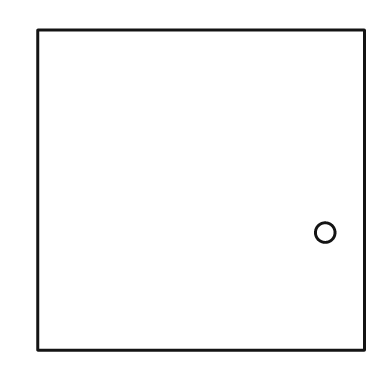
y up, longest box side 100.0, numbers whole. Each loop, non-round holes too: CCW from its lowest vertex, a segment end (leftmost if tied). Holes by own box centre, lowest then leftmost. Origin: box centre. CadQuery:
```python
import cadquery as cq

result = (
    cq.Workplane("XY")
    .moveTo(-50.0, -49.0)
    .lineTo(50.0, -49.0)
    .lineTo(50.0, 49.0)
    .lineTo(-50.0, 49.0)
    .close()
    .moveTo(38.0, -13.0)
    .circle(3.0)
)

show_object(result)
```